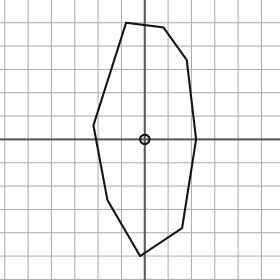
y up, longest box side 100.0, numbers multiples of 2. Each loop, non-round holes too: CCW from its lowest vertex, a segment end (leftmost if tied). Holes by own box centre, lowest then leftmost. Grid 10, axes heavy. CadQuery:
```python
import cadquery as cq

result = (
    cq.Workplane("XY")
    .moveTo(-2.0, -50.0)
    .lineTo(16.0, -38.0)
    .lineTo(22.0, 0.0)
    .lineTo(18.0, 34.0)
    .lineTo(8.0, 48.0)
    .lineTo(-8.0, 50.0)
    .lineTo(-22.0, 6.0)
    .lineTo(-16.0, -26.0)
    .close()
    .moveTo(0.0, 0.0)
    .circle(2.0)
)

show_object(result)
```